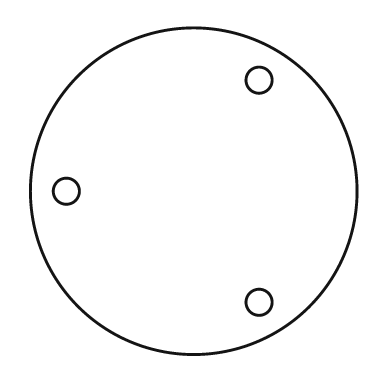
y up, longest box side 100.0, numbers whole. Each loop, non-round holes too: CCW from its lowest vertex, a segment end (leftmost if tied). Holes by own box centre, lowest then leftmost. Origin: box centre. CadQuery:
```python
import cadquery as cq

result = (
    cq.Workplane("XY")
    .moveTo(0.0, 0.0)
    .circle(50.0)
    .moveTo(20.0, -34.0)
    .circle(4.0)
    .moveTo(-39.0, 0.0)
    .circle(4.0)
    .moveTo(20.0, 34.0)
    .circle(4.0)
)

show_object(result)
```